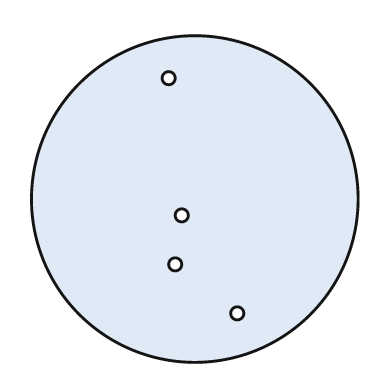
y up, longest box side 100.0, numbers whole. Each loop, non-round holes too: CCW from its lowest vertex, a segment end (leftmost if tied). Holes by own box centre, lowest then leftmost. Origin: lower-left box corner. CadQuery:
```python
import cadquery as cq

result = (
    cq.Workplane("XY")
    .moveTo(50.0, 50.0)
    .circle(50.0)
    .moveTo(63.0, 15.0)
    .circle(2.0)
    .moveTo(44.0, 30.0)
    .circle(2.0)
    .moveTo(46.0, 45.0)
    .circle(2.0)
    .moveTo(42.0, 87.0)
    .circle(2.0)
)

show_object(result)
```